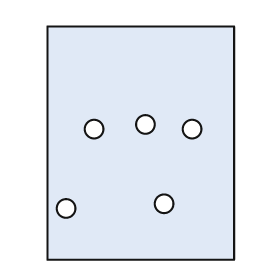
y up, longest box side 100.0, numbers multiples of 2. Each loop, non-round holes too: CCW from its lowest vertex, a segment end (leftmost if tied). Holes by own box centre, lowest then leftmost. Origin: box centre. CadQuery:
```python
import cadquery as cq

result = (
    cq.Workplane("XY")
    .moveTo(-40.0, -50.0)
    .lineTo(40.0, -50.0)
    .lineTo(40.0, 50.0)
    .lineTo(-40.0, 50.0)
    .close()
    .moveTo(-32.0, -28.0)
    .circle(4.0)
    .moveTo(10.0, -26.0)
    .circle(4.0)
    .moveTo(-20.0, 6.0)
    .circle(4.0)
    .moveTo(22.0, 6.0)
    .circle(4.0)
    .moveTo(2.0, 8.0)
    .circle(4.0)
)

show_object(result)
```